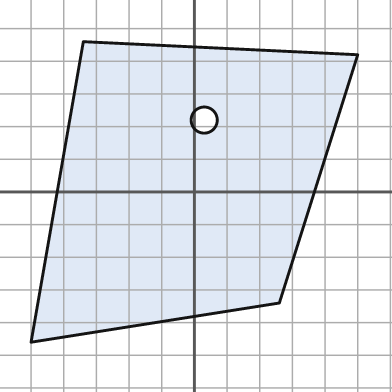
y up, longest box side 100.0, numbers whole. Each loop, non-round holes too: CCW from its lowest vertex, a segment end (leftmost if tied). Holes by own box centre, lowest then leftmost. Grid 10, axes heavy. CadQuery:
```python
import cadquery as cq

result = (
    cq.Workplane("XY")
    .moveTo(-50.0, -46.0)
    .lineTo(26.0, -34.0)
    .lineTo(50.0, 42.0)
    .lineTo(-34.0, 46.0)
    .close()
    .moveTo(3.0, 22.0)
    .circle(4.0)
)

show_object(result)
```